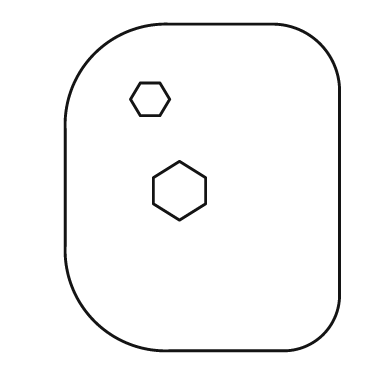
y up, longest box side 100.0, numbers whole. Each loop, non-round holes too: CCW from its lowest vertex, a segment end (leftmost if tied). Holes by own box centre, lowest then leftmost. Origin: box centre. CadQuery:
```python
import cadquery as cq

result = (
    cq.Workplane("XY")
    .moveTo(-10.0, -50.0)
    .lineTo(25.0, -50.0)
    .threePointArc((37.0, -45.0), (42.0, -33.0))
    .lineTo(42.0, 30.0)
    .threePointArc((36.0, 44.0), (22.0, 50.0))
    .lineTo(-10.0, 50.0)
    .threePointArc((-33.0, 41.0), (-42.0, 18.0))
    .lineTo(-42.0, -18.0)
    .threePointArc((-33.0, -41.0), (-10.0, -50.0))
    .close()
    .moveTo(-7.0, -10.0)
    .lineTo(1.0, -5.0)
    .lineTo(1.0, 3.0)
    .lineTo(-7.0, 8.0)
    .lineTo(-15.0, 3.0)
    .lineTo(-15.0, -5.0)
    .close()
    .moveTo(-19.0, 22.0)
    .lineTo(-13.0, 22.0)
    .lineTo(-10.0, 27.0)
    .lineTo(-13.0, 32.0)
    .lineTo(-19.0, 32.0)
    .lineTo(-22.0, 27.0)
    .close()
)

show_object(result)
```